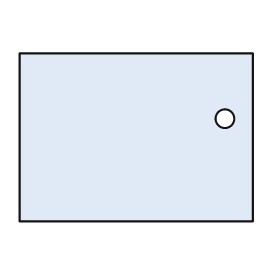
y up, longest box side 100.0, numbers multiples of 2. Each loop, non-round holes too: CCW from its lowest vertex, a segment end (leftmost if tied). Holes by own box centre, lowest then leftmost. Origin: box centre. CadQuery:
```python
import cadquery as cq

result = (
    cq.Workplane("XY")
    .moveTo(-50.0, -36.0)
    .lineTo(50.0, -36.0)
    .lineTo(50.0, 36.0)
    .lineTo(-50.0, 36.0)
    .close()
    .moveTo(38.0, 8.0)
    .circle(4.0)
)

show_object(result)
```